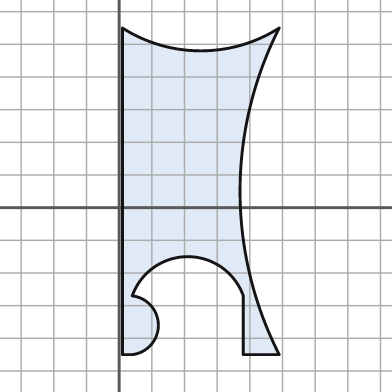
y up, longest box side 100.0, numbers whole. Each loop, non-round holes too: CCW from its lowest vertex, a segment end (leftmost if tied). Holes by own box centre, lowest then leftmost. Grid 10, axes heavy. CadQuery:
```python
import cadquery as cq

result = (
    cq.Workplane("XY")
    .moveTo(1.0, -45.0)
    .lineTo(4.0, -45.0)
    .threePointArc((12.0, -36.0), (4.0, -27.0))
    .threePointArc((21.0, -15.0), (38.0, -27.0))
    .lineTo(38.0, -45.0)
    .lineTo(49.0, -45.0)
    .threePointArc((37.0, 5.0), (49.0, 55.0))
    .threePointArc((25.0, 48.0), (1.0, 55.0))
    .close()
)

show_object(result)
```